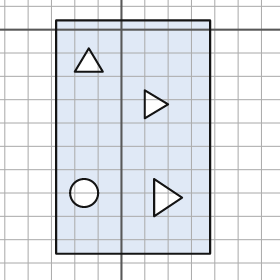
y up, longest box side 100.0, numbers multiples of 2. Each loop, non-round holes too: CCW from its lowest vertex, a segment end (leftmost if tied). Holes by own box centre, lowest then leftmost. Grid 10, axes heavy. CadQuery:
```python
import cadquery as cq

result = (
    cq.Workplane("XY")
    .moveTo(-28.0, -96.0)
    .lineTo(38.0, -96.0)
    .lineTo(38.0, 4.0)
    .lineTo(-28.0, 4.0)
    .close()
    .moveTo(14.0, -80.0)
    .lineTo(26.0, -72.0)
    .lineTo(14.0, -64.0)
    .close()
    .moveTo(-16.0, -70.0)
    .circle(6.0)
    .moveTo(10.0, -38.0)
    .lineTo(20.0, -32.0)
    .lineTo(10.0, -26.0)
    .close()
    .moveTo(-20.0, -18.0)
    .lineTo(-8.0, -18.0)
    .lineTo(-14.0, -8.0)
    .close()
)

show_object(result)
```